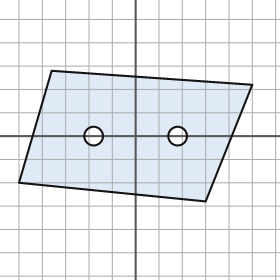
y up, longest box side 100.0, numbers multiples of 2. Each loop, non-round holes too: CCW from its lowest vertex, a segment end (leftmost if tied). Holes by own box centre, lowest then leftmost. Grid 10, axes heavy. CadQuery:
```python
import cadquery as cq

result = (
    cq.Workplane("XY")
    .moveTo(30.0, -28.0)
    .lineTo(50.0, 22.0)
    .lineTo(-36.0, 28.0)
    .lineTo(-50.0, -20.0)
    .close()
    .moveTo(-18.0, 0.0)
    .circle(4.0)
    .moveTo(18.0, 0.0)
    .circle(4.0)
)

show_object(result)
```